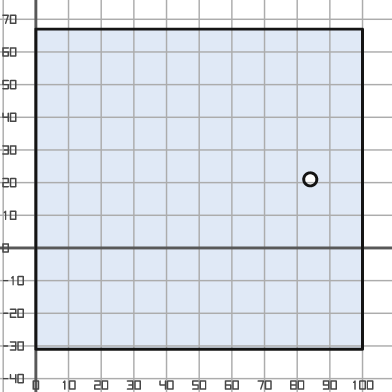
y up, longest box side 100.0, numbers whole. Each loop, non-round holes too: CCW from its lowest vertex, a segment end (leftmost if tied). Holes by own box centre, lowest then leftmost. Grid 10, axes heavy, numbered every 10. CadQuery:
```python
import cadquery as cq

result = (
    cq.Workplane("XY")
    .moveTo(0.0, -31.0)
    .lineTo(100.0, -31.0)
    .lineTo(100.0, 67.0)
    .lineTo(0.0, 67.0)
    .close()
    .moveTo(84.0, 21.0)
    .circle(2.0)
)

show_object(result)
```